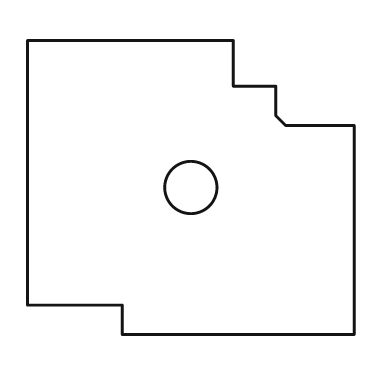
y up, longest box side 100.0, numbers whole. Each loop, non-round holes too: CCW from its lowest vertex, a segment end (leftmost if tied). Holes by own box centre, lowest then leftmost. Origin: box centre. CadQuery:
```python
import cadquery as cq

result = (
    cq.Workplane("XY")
    .moveTo(-21.0, -45.0)
    .lineTo(50.0, -45.0)
    .lineTo(50.0, 19.0)
    .lineTo(29.0, 19.0)
    .lineTo(26.0, 22.0)
    .lineTo(26.0, 31.0)
    .lineTo(13.0, 31.0)
    .lineTo(13.0, 45.0)
    .lineTo(-50.0, 45.0)
    .lineTo(-50.0, -36.0)
    .lineTo(-21.0, -36.0)
    .close()
    .moveTo(0.0, 0.0)
    .circle(8.0)
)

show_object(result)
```